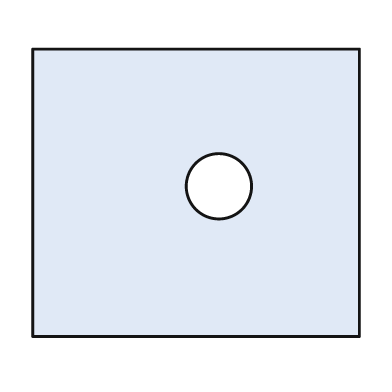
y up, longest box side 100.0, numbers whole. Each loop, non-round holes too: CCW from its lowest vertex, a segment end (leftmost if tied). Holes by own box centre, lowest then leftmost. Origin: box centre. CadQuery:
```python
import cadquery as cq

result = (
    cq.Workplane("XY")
    .moveTo(-50.0, -44.0)
    .lineTo(50.0, -44.0)
    .lineTo(50.0, 44.0)
    .lineTo(-50.0, 44.0)
    .close()
    .moveTo(7.0, 2.0)
    .circle(10.0)
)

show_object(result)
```